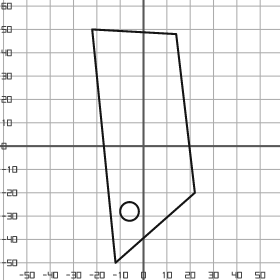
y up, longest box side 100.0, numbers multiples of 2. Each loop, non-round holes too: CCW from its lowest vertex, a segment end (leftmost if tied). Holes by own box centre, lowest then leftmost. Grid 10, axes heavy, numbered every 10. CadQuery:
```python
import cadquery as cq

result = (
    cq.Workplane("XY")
    .moveTo(-12.0, -50.0)
    .lineTo(22.0, -20.0)
    .lineTo(14.0, 48.0)
    .lineTo(-22.0, 50.0)
    .close()
    .moveTo(-6.0, -28.0)
    .circle(4.0)
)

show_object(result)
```